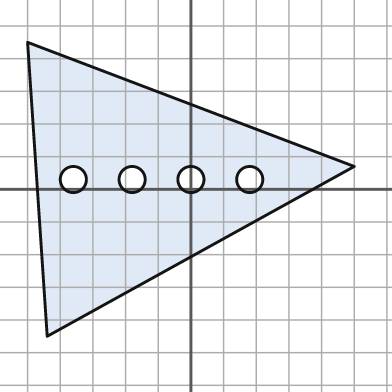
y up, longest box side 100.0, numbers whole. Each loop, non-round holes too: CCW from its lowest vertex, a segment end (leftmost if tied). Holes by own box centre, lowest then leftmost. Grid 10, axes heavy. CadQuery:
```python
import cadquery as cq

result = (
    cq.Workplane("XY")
    .moveTo(-44.0, -45.0)
    .lineTo(50.0, 7.0)
    .lineTo(-50.0, 45.0)
    .close()
    .moveTo(-36.0, 3.0)
    .circle(4.0)
    .moveTo(-18.0, 3.0)
    .circle(4.0)
    .moveTo(0.0, 3.0)
    .circle(4.0)
    .moveTo(18.0, 3.0)
    .circle(4.0)
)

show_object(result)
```